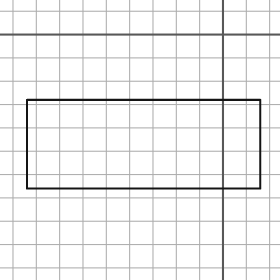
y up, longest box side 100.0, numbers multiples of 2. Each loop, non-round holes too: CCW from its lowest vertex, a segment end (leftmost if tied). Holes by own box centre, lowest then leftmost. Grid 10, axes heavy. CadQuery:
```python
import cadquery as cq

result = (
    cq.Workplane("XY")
    .moveTo(-84.0, -66.0)
    .lineTo(16.0, -66.0)
    .lineTo(16.0, -28.0)
    .lineTo(-84.0, -28.0)
    .close()
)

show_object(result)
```